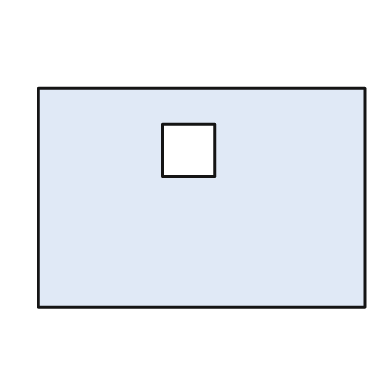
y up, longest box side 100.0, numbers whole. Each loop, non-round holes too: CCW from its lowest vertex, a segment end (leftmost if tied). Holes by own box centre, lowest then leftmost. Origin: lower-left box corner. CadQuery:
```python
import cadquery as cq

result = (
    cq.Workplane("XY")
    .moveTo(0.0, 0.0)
    .lineTo(100.0, 0.0)
    .lineTo(100.0, 67.0)
    .lineTo(0.0, 67.0)
    .close()
    .moveTo(38.0, 40.0)
    .lineTo(54.0, 40.0)
    .lineTo(54.0, 56.0)
    .lineTo(38.0, 56.0)
    .close()
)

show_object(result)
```